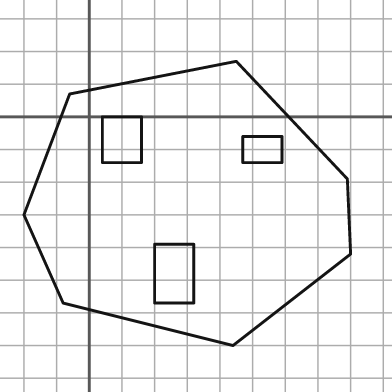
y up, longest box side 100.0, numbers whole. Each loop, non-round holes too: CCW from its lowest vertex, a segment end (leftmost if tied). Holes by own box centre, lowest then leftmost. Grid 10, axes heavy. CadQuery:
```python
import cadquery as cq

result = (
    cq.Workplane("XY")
    .moveTo(44.0, -70.0)
    .lineTo(80.0, -42.0)
    .lineTo(79.0, -19.0)
    .lineTo(45.0, 17.0)
    .lineTo(-6.0, 7.0)
    .lineTo(-20.0, -30.0)
    .lineTo(-8.0, -57.0)
    .close()
    .moveTo(20.0, -57.0)
    .lineTo(32.0, -57.0)
    .lineTo(32.0, -39.0)
    .lineTo(20.0, -39.0)
    .close()
    .moveTo(47.0, -14.0)
    .lineTo(59.0, -14.0)
    .lineTo(59.0, -6.0)
    .lineTo(47.0, -6.0)
    .close()
    .moveTo(4.0, -14.0)
    .lineTo(16.0, -14.0)
    .lineTo(16.0, 0.0)
    .lineTo(4.0, 0.0)
    .close()
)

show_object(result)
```